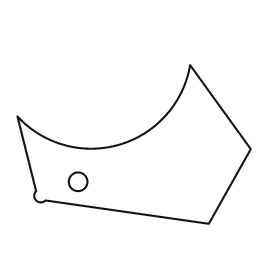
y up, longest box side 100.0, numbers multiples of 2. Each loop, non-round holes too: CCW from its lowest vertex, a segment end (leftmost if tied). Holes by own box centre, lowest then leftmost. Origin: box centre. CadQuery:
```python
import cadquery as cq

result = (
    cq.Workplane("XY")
    .moveTo(32.0, -34.0)
    .lineTo(50.0, -2.0)
    .lineTo(24.0, 34.0)
    .threePointArc((-6.0, 0.0), (-50.0, 12.0))
    .lineTo(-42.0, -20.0)
    .threePointArc((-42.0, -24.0), (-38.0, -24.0))
    .close()
    .moveTo(-24.0, -16.0)
    .circle(4.0)
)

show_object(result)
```